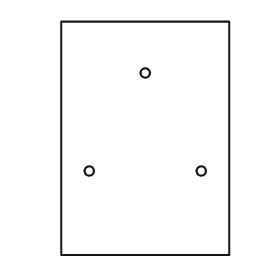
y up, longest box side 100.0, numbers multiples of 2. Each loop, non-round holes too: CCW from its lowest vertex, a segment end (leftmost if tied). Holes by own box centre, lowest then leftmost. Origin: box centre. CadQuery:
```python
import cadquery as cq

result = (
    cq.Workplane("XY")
    .moveTo(-36.0, -50.0)
    .lineTo(36.0, -50.0)
    .lineTo(36.0, 50.0)
    .lineTo(-36.0, 50.0)
    .close()
    .moveTo(-24.0, -14.0)
    .circle(2.0)
    .moveTo(24.0, -14.0)
    .circle(2.0)
    .moveTo(0.0, 28.0)
    .circle(2.0)
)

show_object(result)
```